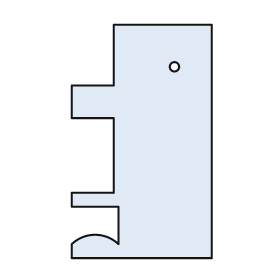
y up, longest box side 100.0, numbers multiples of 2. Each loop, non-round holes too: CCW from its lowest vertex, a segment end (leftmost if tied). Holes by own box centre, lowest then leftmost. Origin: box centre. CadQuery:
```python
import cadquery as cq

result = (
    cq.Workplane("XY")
    .moveTo(-30.0, -50.0)
    .lineTo(30.0, -50.0)
    .lineTo(30.0, 50.0)
    .lineTo(-12.0, 50.0)
    .lineTo(-12.0, 24.0)
    .lineTo(-30.0, 24.0)
    .lineTo(-30.0, 10.0)
    .lineTo(-12.0, 10.0)
    .lineTo(-12.0, -22.0)
    .lineTo(-30.0, -22.0)
    .lineTo(-30.0, -28.0)
    .lineTo(-10.0, -28.0)
    .lineTo(-10.0, -44.0)
    .threePointArc((-20.0, -40.0), (-30.0, -44.0))
    .close()
    .moveTo(14.0, 32.0)
    .circle(2.0)
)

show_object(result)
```